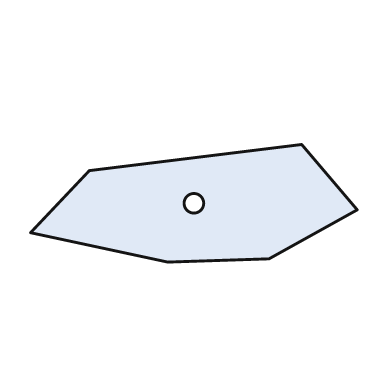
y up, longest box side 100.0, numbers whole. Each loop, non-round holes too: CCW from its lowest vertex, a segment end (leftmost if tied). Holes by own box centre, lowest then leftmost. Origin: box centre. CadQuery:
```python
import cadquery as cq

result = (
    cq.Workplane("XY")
    .moveTo(-8.0, -18.0)
    .lineTo(23.0, -17.0)
    .lineTo(50.0, -2.0)
    .lineTo(33.0, 18.0)
    .lineTo(-32.0, 10.0)
    .lineTo(-50.0, -9.0)
    .close()
    .moveTo(0.0, 0.0)
    .circle(3.0)
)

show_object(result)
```